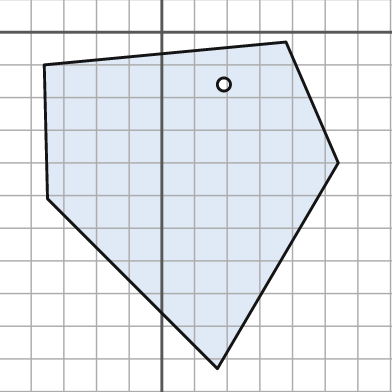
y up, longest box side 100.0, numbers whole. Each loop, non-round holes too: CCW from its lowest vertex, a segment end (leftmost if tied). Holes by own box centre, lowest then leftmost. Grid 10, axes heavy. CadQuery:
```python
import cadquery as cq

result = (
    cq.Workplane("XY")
    .moveTo(17.0, -103.0)
    .lineTo(54.0, -40.0)
    .lineTo(38.0, -3.0)
    .lineTo(-36.0, -10.0)
    .lineTo(-35.0, -51.0)
    .close()
    .moveTo(19.0, -16.0)
    .circle(2.0)
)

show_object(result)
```